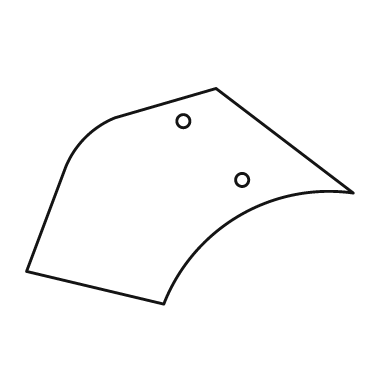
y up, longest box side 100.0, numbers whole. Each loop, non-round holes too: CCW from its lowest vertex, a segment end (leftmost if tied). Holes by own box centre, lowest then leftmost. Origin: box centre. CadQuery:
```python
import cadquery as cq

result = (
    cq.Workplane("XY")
    .moveTo(-8.0, -33.0)
    .threePointArc((15.0, -6.0), (50.0, 1.0))
    .lineTo(8.0, 33.0)
    .lineTo(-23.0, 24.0)
    .threePointArc((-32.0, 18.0), (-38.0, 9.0))
    .lineTo(-50.0, -23.0)
    .close()
    .moveTo(16.0, 5.0)
    .circle(2.0)
    .moveTo(-2.0, 23.0)
    .circle(2.0)
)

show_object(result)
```